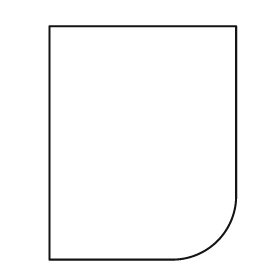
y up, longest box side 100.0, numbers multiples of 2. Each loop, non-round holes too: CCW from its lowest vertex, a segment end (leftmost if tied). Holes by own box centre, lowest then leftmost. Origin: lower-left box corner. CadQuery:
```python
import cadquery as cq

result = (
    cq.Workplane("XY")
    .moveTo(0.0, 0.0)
    .lineTo(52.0, 0.0)
    .threePointArc((72.0, 8.0), (80.0, 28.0))
    .lineTo(80.0, 100.0)
    .lineTo(0.0, 100.0)
    .close()
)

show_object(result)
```